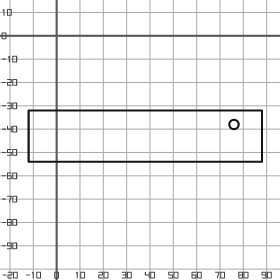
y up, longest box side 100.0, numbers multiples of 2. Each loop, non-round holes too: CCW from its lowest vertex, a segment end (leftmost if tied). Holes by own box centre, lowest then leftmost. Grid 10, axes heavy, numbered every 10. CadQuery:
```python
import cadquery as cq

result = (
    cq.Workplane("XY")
    .moveTo(-12.0, -54.0)
    .lineTo(88.0, -54.0)
    .lineTo(88.0, -32.0)
    .lineTo(-12.0, -32.0)
    .close()
    .moveTo(76.0, -38.0)
    .circle(2.0)
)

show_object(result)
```